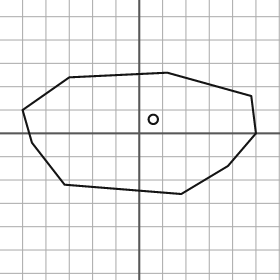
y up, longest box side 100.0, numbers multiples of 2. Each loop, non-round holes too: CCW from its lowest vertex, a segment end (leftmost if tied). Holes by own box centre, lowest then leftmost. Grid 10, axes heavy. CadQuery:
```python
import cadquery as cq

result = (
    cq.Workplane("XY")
    .moveTo(18.0, -26.0)
    .lineTo(38.0, -14.0)
    .lineTo(50.0, 0.0)
    .lineTo(48.0, 16.0)
    .lineTo(12.0, 26.0)
    .lineTo(-30.0, 24.0)
    .lineTo(-50.0, 10.0)
    .lineTo(-46.0, -4.0)
    .lineTo(-32.0, -22.0)
    .close()
    .moveTo(6.0, 6.0)
    .circle(2.0)
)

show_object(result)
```